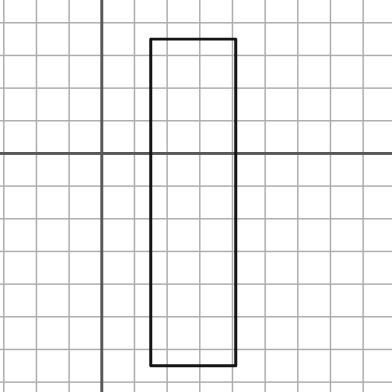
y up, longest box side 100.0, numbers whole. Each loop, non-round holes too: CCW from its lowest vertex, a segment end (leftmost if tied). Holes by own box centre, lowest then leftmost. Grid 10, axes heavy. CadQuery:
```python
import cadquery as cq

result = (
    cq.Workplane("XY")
    .moveTo(15.0, -65.0)
    .lineTo(41.0, -65.0)
    .lineTo(41.0, 35.0)
    .lineTo(15.0, 35.0)
    .close()
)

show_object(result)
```